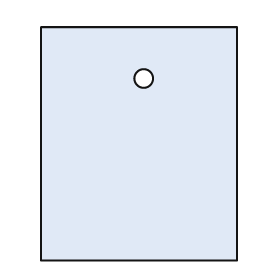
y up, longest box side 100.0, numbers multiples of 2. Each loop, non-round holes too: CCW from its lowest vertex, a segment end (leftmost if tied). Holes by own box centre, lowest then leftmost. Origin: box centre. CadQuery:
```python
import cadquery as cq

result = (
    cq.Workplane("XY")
    .moveTo(-42.0, -50.0)
    .lineTo(42.0, -50.0)
    .lineTo(42.0, 50.0)
    .lineTo(-42.0, 50.0)
    .close()
    .moveTo(2.0, 28.0)
    .circle(4.0)
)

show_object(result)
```